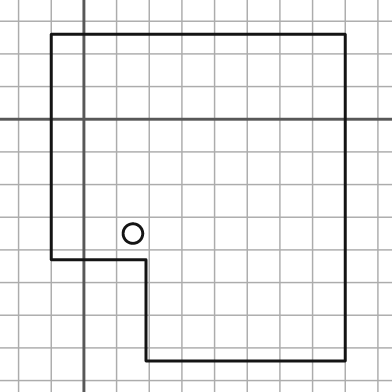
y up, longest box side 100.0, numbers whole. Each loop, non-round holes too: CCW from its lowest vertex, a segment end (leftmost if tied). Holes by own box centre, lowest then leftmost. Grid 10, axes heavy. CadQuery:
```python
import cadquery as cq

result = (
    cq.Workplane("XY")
    .moveTo(19.0, -74.0)
    .lineTo(80.0, -74.0)
    .lineTo(80.0, 26.0)
    .lineTo(-10.0, 26.0)
    .lineTo(-10.0, -43.0)
    .lineTo(19.0, -43.0)
    .close()
    .moveTo(15.0, -35.0)
    .circle(3.0)
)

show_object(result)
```